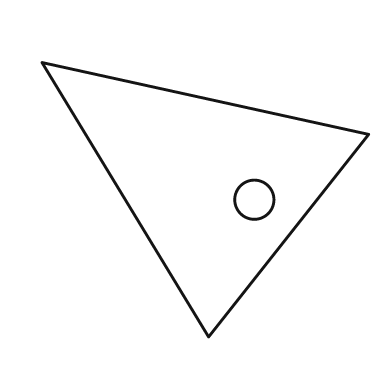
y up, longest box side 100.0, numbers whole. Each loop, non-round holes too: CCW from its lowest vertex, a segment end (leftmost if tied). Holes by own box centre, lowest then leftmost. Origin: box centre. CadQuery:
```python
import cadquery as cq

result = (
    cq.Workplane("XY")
    .moveTo(1.0, -42.0)
    .lineTo(50.0, 20.0)
    .lineTo(-50.0, 42.0)
    .close()
    .moveTo(15.0, 0.0)
    .circle(6.0)
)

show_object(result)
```